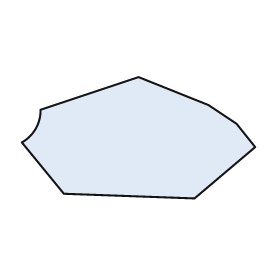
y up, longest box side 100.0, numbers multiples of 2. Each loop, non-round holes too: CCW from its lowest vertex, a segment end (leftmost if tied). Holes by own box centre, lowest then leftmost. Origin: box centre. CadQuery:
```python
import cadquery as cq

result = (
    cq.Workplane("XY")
    .moveTo(24.0, -26.0)
    .lineTo(50.0, -4.0)
    .lineTo(42.0, 6.0)
    .lineTo(30.0, 14.0)
    .lineTo(0.0, 26.0)
    .lineTo(-42.0, 12.0)
    .threePointArc((-44.0, 4.0), (-50.0, -2.0))
    .lineTo(-32.0, -24.0)
    .close()
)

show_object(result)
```